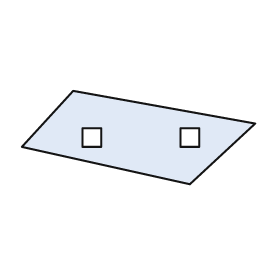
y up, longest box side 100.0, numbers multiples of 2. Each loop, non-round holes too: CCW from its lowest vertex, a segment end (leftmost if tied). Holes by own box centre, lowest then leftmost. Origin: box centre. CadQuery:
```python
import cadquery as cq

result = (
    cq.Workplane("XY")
    .moveTo(22.0, -20.0)
    .lineTo(50.0, 6.0)
    .lineTo(-28.0, 20.0)
    .lineTo(-50.0, -4.0)
    .close()
    .moveTo(-24.0, -4.0)
    .lineTo(-16.0, -4.0)
    .lineTo(-16.0, 4.0)
    .lineTo(-24.0, 4.0)
    .close()
    .moveTo(18.0, -4.0)
    .lineTo(26.0, -4.0)
    .lineTo(26.0, 4.0)
    .lineTo(18.0, 4.0)
    .close()
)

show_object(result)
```